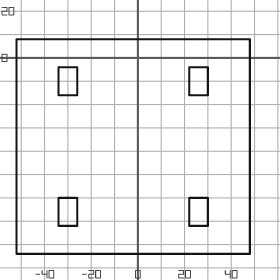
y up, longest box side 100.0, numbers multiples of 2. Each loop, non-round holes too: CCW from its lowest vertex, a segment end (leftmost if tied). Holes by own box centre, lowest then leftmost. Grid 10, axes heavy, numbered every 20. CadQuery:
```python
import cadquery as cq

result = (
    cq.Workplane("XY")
    .moveTo(-52.0, -84.0)
    .lineTo(48.0, -84.0)
    .lineTo(48.0, 8.0)
    .lineTo(-52.0, 8.0)
    .close()
    .moveTo(-34.0, -72.0)
    .lineTo(-26.0, -72.0)
    .lineTo(-26.0, -60.0)
    .lineTo(-34.0, -60.0)
    .close()
    .moveTo(22.0, -72.0)
    .lineTo(30.0, -72.0)
    .lineTo(30.0, -60.0)
    .lineTo(22.0, -60.0)
    .close()
    .moveTo(-34.0, -16.0)
    .lineTo(-26.0, -16.0)
    .lineTo(-26.0, -4.0)
    .lineTo(-34.0, -4.0)
    .close()
    .moveTo(22.0, -16.0)
    .lineTo(30.0, -16.0)
    .lineTo(30.0, -4.0)
    .lineTo(22.0, -4.0)
    .close()
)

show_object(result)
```